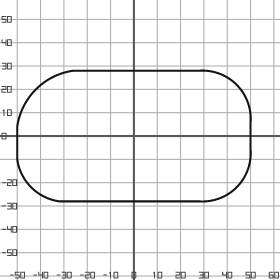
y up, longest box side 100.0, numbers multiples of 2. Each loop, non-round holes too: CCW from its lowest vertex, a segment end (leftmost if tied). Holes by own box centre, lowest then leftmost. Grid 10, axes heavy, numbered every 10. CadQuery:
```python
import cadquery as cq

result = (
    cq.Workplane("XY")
    .moveTo(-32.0, -28.0)
    .lineTo(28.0, -28.0)
    .threePointArc((44.0, -22.0), (50.0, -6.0))
    .lineTo(50.0, 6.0)
    .threePointArc((44.0, 22.0), (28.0, 28.0))
    .lineTo(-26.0, 28.0)
    .threePointArc((-42.0, 20.0), (-50.0, 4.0))
    .lineTo(-50.0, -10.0)
    .threePointArc((-44.0, -22.0), (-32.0, -28.0))
    .close()
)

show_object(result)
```